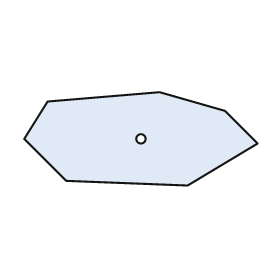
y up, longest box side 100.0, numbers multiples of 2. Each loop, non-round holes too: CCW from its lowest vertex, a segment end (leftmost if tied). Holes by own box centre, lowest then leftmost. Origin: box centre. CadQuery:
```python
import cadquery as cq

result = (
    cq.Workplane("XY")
    .moveTo(20.0, -20.0)
    .lineTo(50.0, -2.0)
    .lineTo(36.0, 12.0)
    .lineTo(8.0, 20.0)
    .lineTo(-40.0, 16.0)
    .lineTo(-50.0, 0.0)
    .lineTo(-32.0, -18.0)
    .close()
    .moveTo(0.0, 0.0)
    .circle(2.0)
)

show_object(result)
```